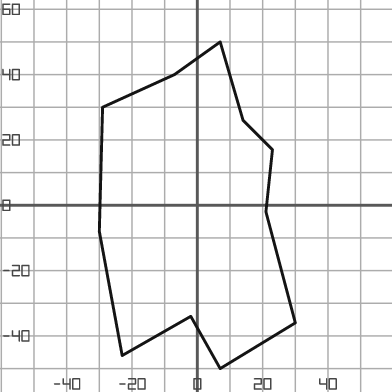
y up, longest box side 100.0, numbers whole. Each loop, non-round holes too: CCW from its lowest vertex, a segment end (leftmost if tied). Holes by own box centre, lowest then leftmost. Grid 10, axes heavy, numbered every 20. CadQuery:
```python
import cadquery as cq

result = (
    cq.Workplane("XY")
    .moveTo(7.0, -50.0)
    .lineTo(30.0, -36.0)
    .lineTo(21.0, -2.0)
    .lineTo(23.0, 17.0)
    .lineTo(14.0, 26.0)
    .lineTo(7.0, 50.0)
    .lineTo(-7.0, 40.0)
    .lineTo(-29.0, 30.0)
    .lineTo(-30.0, -8.0)
    .lineTo(-23.0, -46.0)
    .lineTo(-2.0, -34.0)
    .close()
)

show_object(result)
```